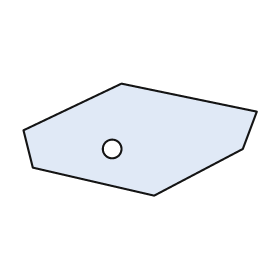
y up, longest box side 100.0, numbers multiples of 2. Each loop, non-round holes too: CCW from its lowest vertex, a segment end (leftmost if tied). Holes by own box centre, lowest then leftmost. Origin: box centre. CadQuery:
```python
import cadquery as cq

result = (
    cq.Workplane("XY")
    .moveTo(6.0, -24.0)
    .lineTo(44.0, -4.0)
    .lineTo(50.0, 12.0)
    .lineTo(-8.0, 24.0)
    .lineTo(-50.0, 4.0)
    .lineTo(-46.0, -12.0)
    .close()
    .moveTo(-12.0, -4.0)
    .circle(4.0)
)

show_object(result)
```